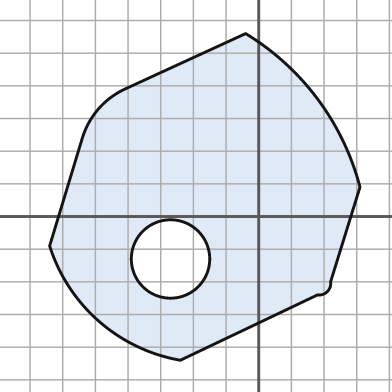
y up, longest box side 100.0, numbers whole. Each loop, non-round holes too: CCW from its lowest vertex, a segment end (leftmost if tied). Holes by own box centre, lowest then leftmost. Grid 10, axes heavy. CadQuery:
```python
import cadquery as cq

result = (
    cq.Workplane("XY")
    .moveTo(-24.0, -44.0)
    .lineTo(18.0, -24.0)
    .threePointArc((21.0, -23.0), (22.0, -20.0))
    .lineTo(31.0, 9.0)
    .threePointArc((18.0, 36.0), (-4.0, 56.0))
    .lineTo(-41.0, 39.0)
    .threePointArc((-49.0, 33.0), (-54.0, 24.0))
    .lineTo(-64.0, -9.0)
    .threePointArc((-49.0, -32.0), (-24.0, -44.0))
    .close()
    .moveTo(-27.0, -13.0)
    .circle(12.0)
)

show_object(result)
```